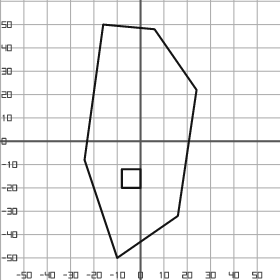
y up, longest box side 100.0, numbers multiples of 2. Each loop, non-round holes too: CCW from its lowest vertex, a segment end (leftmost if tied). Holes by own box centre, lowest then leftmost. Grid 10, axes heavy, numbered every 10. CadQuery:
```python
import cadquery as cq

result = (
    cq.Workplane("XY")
    .moveTo(-10.0, -50.0)
    .lineTo(16.0, -32.0)
    .lineTo(24.0, 22.0)
    .lineTo(6.0, 48.0)
    .lineTo(-16.0, 50.0)
    .lineTo(-24.0, -8.0)
    .close()
    .moveTo(-8.0, -20.0)
    .lineTo(0.0, -20.0)
    .lineTo(0.0, -12.0)
    .lineTo(-8.0, -12.0)
    .close()
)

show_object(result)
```